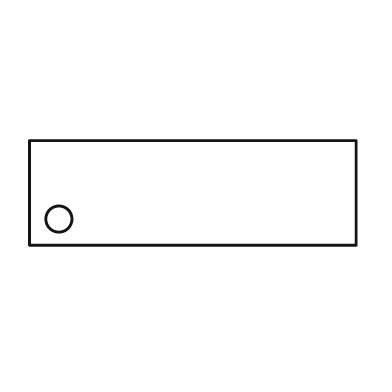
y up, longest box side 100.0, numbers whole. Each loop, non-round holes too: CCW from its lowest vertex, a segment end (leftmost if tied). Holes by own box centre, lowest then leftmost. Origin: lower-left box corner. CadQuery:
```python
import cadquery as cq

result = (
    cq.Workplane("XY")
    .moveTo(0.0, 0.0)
    .lineTo(100.0, 0.0)
    .lineTo(100.0, 32.0)
    .lineTo(0.0, 32.0)
    .close()
    .moveTo(9.0, 8.0)
    .circle(4.0)
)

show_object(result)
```